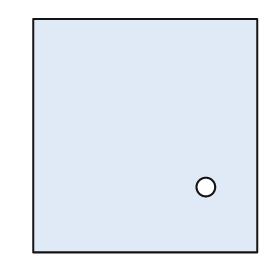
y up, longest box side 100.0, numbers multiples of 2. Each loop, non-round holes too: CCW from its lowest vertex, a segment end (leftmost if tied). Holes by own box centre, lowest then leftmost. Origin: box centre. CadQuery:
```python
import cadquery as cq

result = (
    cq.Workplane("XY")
    .moveTo(-48.0, -50.0)
    .lineTo(48.0, -50.0)
    .lineTo(48.0, 50.0)
    .lineTo(-48.0, 50.0)
    .close()
    .moveTo(26.0, -22.0)
    .circle(4.0)
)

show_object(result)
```